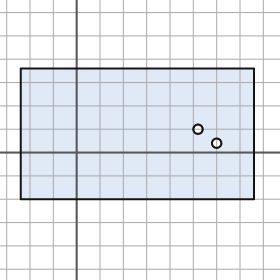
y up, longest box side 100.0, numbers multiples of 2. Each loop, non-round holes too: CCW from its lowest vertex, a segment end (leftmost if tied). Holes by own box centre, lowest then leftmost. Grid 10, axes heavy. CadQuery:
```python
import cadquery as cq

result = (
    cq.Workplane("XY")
    .moveTo(-24.0, -20.0)
    .lineTo(76.0, -20.0)
    .lineTo(76.0, 36.0)
    .lineTo(-24.0, 36.0)
    .close()
    .moveTo(60.0, 4.0)
    .circle(2.0)
    .moveTo(52.0, 10.0)
    .circle(2.0)
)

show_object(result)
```